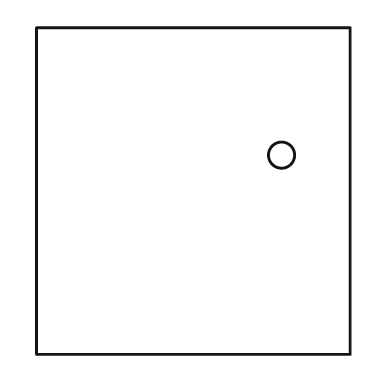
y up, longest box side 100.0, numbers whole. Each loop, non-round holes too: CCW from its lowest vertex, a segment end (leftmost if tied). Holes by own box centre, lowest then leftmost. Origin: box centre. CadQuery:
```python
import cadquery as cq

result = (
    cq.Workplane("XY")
    .moveTo(-48.0, -50.0)
    .lineTo(48.0, -50.0)
    .lineTo(48.0, 50.0)
    .lineTo(-48.0, 50.0)
    .close()
    .moveTo(27.0, 11.0)
    .circle(4.0)
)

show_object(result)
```